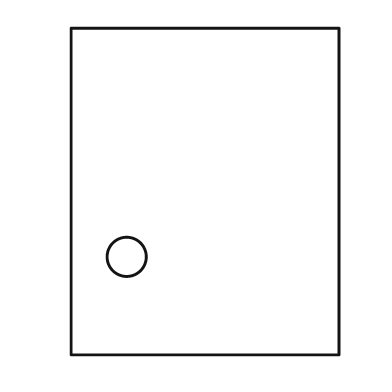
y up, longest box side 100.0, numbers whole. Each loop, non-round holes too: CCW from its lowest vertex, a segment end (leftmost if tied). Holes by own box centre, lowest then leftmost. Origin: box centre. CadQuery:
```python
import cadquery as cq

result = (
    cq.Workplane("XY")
    .moveTo(-41.0, -50.0)
    .lineTo(41.0, -50.0)
    .lineTo(41.0, 50.0)
    .lineTo(-41.0, 50.0)
    .close()
    .moveTo(-24.0, -20.0)
    .circle(6.0)
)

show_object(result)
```